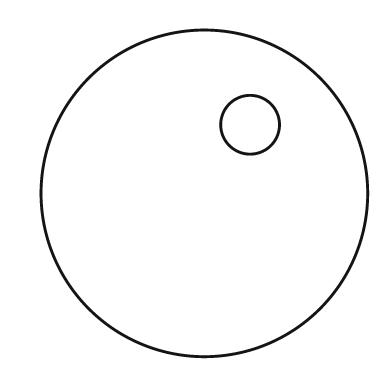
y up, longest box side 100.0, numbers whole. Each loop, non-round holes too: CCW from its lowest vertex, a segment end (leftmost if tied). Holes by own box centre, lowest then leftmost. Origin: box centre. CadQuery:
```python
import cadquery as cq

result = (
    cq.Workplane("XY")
    .moveTo(0.0, 0.0)
    .circle(50.0)
    .moveTo(14.0, 21.0)
    .circle(9.0)
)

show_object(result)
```